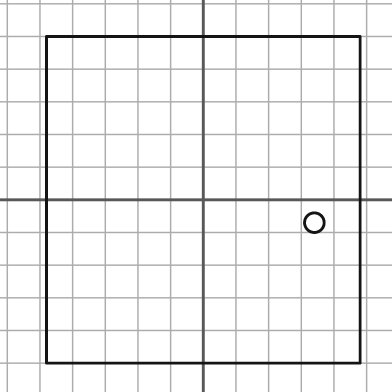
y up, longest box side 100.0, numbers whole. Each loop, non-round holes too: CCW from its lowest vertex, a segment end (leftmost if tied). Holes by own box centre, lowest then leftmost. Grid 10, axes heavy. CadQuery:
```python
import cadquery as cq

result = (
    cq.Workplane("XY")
    .moveTo(-48.0, -50.0)
    .lineTo(48.0, -50.0)
    .lineTo(48.0, 50.0)
    .lineTo(-48.0, 50.0)
    .close()
    .moveTo(34.0, -7.0)
    .circle(3.0)
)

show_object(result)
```